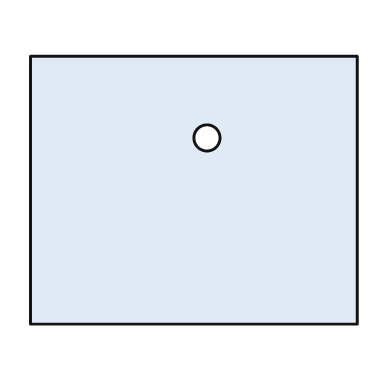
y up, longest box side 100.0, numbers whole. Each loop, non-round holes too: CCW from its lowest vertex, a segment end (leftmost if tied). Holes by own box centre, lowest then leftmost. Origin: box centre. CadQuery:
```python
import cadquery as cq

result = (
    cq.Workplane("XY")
    .moveTo(-50.0, -41.0)
    .lineTo(50.0, -41.0)
    .lineTo(50.0, 41.0)
    .lineTo(-50.0, 41.0)
    .close()
    .moveTo(4.0, 16.0)
    .circle(4.0)
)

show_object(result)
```